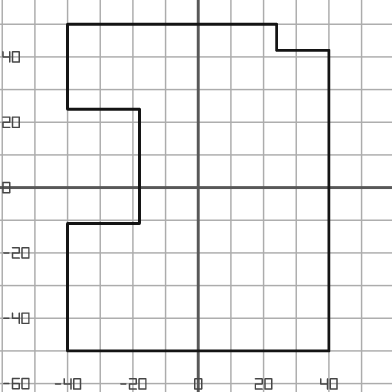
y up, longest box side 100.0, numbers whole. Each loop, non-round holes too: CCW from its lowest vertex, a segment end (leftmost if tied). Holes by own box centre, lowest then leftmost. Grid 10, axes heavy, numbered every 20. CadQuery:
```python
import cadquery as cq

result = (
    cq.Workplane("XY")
    .moveTo(-40.0, -50.0)
    .lineTo(40.0, -50.0)
    .lineTo(40.0, 42.0)
    .lineTo(24.0, 42.0)
    .lineTo(24.0, 50.0)
    .lineTo(-40.0, 50.0)
    .lineTo(-40.0, 24.0)
    .lineTo(-18.0, 24.0)
    .lineTo(-18.0, -11.0)
    .lineTo(-40.0, -11.0)
    .close()
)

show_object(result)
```